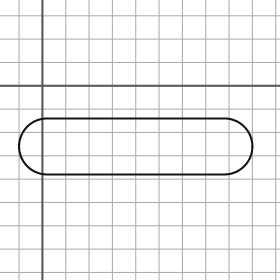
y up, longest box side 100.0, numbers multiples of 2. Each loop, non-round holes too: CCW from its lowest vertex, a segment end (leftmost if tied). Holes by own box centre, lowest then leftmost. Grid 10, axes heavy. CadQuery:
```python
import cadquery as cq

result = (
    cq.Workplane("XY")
    .moveTo(2.0, -38.0)
    .lineTo(78.0, -38.0)
    .threePointArc((90.0, -26.0), (78.0, -14.0))
    .lineTo(2.0, -14.0)
    .threePointArc((-10.0, -26.0), (2.0, -38.0))
    .close()
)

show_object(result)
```